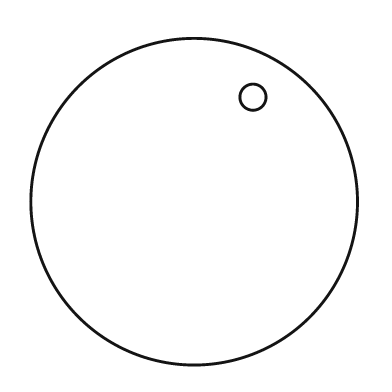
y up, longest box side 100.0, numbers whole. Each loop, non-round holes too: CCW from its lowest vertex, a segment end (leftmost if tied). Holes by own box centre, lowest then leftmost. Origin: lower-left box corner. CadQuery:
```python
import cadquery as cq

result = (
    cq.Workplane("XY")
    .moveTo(50.0, 50.0)
    .circle(50.0)
    .moveTo(68.0, 82.0)
    .circle(4.0)
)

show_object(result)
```